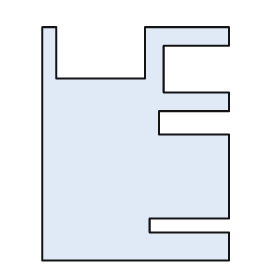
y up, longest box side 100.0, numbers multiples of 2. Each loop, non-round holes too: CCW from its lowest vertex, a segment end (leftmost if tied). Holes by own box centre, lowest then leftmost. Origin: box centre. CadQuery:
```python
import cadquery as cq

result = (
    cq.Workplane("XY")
    .moveTo(-40.0, -50.0)
    .lineTo(40.0, -50.0)
    .lineTo(40.0, -38.0)
    .lineTo(6.0, -38.0)
    .lineTo(6.0, -32.0)
    .lineTo(40.0, -32.0)
    .lineTo(40.0, 4.0)
    .lineTo(10.0, 4.0)
    .lineTo(10.0, 14.0)
    .lineTo(40.0, 14.0)
    .lineTo(40.0, 22.0)
    .lineTo(12.0, 22.0)
    .lineTo(12.0, 42.0)
    .lineTo(40.0, 42.0)
    .lineTo(40.0, 50.0)
    .lineTo(4.0, 50.0)
    .lineTo(4.0, 28.0)
    .lineTo(-34.0, 28.0)
    .lineTo(-34.0, 50.0)
    .lineTo(-40.0, 50.0)
    .close()
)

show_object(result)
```